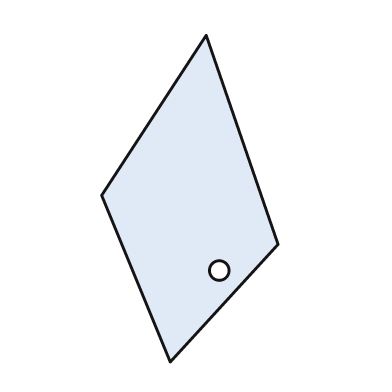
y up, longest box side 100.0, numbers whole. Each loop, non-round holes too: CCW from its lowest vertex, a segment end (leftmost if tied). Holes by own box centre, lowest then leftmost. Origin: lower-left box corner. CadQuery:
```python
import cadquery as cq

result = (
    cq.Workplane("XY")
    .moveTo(21.0, 0.0)
    .lineTo(54.0, 36.0)
    .lineTo(32.0, 100.0)
    .lineTo(0.0, 51.0)
    .close()
    .moveTo(36.0, 28.0)
    .circle(3.0)
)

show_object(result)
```